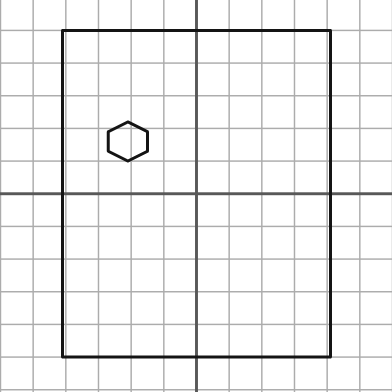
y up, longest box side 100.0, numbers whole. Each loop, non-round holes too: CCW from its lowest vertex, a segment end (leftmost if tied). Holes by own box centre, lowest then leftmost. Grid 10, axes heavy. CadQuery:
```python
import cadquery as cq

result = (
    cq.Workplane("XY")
    .moveTo(-41.0, -50.0)
    .lineTo(41.0, -50.0)
    .lineTo(41.0, 50.0)
    .lineTo(-41.0, 50.0)
    .close()
    .moveTo(-21.0, 10.0)
    .lineTo(-15.0, 13.0)
    .lineTo(-15.0, 19.0)
    .lineTo(-21.0, 22.0)
    .lineTo(-27.0, 19.0)
    .lineTo(-27.0, 13.0)
    .close()
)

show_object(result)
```